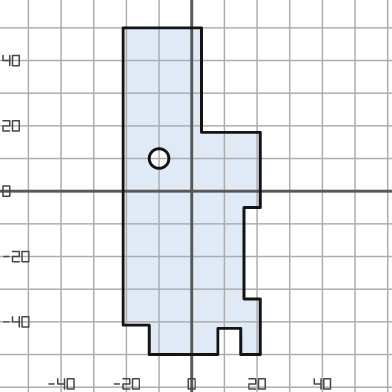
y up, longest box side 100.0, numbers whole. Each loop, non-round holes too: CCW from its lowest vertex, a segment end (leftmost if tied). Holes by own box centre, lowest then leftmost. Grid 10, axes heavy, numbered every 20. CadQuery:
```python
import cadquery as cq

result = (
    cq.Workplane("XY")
    .moveTo(-13.0, -50.0)
    .lineTo(8.0, -50.0)
    .lineTo(8.0, -42.0)
    .lineTo(15.0, -42.0)
    .lineTo(15.0, -50.0)
    .lineTo(21.0, -50.0)
    .lineTo(21.0, -33.0)
    .lineTo(16.0, -33.0)
    .lineTo(16.0, -5.0)
    .lineTo(21.0, -5.0)
    .lineTo(21.0, 18.0)
    .lineTo(3.0, 18.0)
    .lineTo(3.0, 50.0)
    .lineTo(-21.0, 50.0)
    .lineTo(-21.0, -41.0)
    .lineTo(-13.0, -41.0)
    .close()
    .moveTo(-10.0, 10.0)
    .circle(3.0)
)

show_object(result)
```